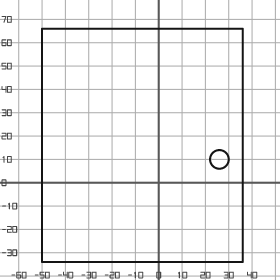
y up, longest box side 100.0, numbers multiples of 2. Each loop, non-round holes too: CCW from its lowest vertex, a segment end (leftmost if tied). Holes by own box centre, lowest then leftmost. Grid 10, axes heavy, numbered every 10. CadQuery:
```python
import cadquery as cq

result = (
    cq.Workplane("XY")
    .moveTo(-50.0, -34.0)
    .lineTo(36.0, -34.0)
    .lineTo(36.0, 66.0)
    .lineTo(-50.0, 66.0)
    .close()
    .moveTo(26.0, 10.0)
    .circle(4.0)
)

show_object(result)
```